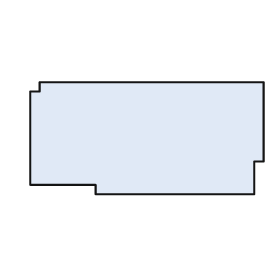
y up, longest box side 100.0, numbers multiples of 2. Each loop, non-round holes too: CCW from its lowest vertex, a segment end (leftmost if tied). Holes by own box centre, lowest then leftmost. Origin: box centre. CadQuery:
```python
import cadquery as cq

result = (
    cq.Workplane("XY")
    .moveTo(-22.0, -24.0)
    .lineTo(46.0, -24.0)
    .lineTo(46.0, -10.0)
    .lineTo(50.0, -10.0)
    .lineTo(50.0, 24.0)
    .lineTo(-46.0, 24.0)
    .lineTo(-46.0, 20.0)
    .lineTo(-50.0, 20.0)
    .lineTo(-50.0, -20.0)
    .lineTo(-22.0, -20.0)
    .close()
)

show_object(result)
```